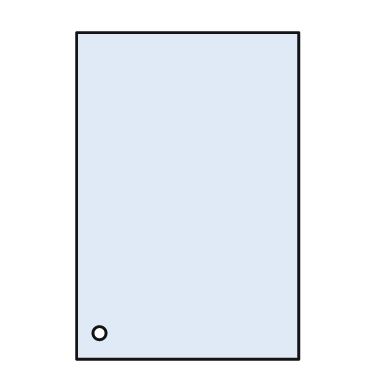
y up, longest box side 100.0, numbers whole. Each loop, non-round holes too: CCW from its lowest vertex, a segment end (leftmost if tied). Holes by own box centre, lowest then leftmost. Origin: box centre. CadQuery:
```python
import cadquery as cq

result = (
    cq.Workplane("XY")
    .moveTo(-34.0, -50.0)
    .lineTo(34.0, -50.0)
    .lineTo(34.0, 50.0)
    .lineTo(-34.0, 50.0)
    .close()
    .moveTo(-27.0, -42.0)
    .circle(2.0)
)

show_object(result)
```